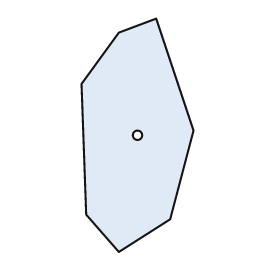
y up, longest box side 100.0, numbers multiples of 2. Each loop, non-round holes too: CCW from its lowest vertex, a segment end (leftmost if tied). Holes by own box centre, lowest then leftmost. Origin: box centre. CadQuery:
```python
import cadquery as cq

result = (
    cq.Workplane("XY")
    .moveTo(-8.0, -50.0)
    .lineTo(14.0, -36.0)
    .lineTo(24.0, 2.0)
    .lineTo(8.0, 50.0)
    .lineTo(-8.0, 44.0)
    .lineTo(-24.0, 22.0)
    .lineTo(-22.0, -34.0)
    .close()
    .moveTo(0.0, 0.0)
    .circle(2.0)
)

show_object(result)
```